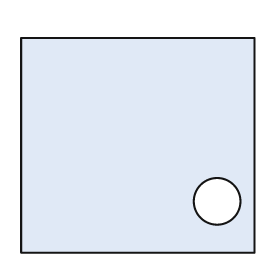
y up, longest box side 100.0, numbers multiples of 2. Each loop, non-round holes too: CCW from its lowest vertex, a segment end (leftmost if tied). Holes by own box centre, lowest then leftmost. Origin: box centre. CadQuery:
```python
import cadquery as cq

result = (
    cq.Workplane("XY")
    .moveTo(-50.0, -46.0)
    .lineTo(50.0, -46.0)
    .lineTo(50.0, 46.0)
    .lineTo(-50.0, 46.0)
    .close()
    .moveTo(34.0, -24.0)
    .circle(10.0)
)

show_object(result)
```